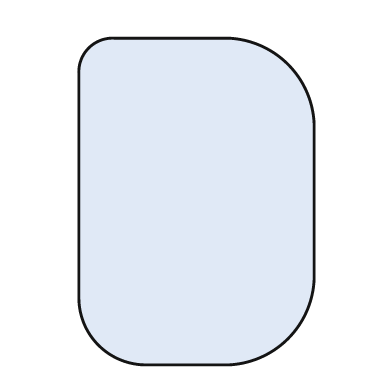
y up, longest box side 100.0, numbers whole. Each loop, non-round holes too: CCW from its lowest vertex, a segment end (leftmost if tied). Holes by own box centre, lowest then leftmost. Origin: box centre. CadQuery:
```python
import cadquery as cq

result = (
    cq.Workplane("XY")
    .moveTo(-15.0, -50.0)
    .lineTo(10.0, -50.0)
    .threePointArc((28.0, -42.0), (36.0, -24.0))
    .lineTo(36.0, 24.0)
    .threePointArc((28.0, 42.0), (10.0, 50.0))
    .lineTo(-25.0, 50.0)
    .threePointArc((-33.0, 47.0), (-36.0, 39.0))
    .lineTo(-36.0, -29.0)
    .threePointArc((-30.0, -44.0), (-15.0, -50.0))
    .close()
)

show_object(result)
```